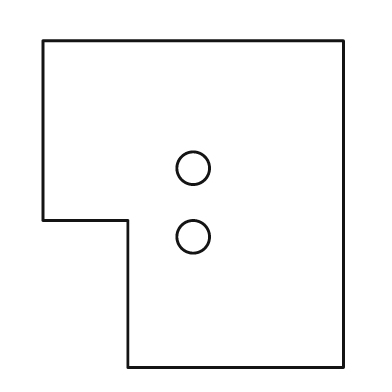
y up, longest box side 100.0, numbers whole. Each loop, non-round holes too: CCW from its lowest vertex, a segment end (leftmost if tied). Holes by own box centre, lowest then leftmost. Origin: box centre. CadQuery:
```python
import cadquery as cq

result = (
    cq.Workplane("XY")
    .moveTo(-20.0, -50.0)
    .lineTo(46.0, -50.0)
    .lineTo(46.0, 50.0)
    .lineTo(-46.0, 50.0)
    .lineTo(-46.0, -5.0)
    .lineTo(-20.0, -5.0)
    .close()
    .moveTo(0.0, -10.0)
    .circle(5.0)
    .moveTo(0.0, 11.0)
    .circle(5.0)
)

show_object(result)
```